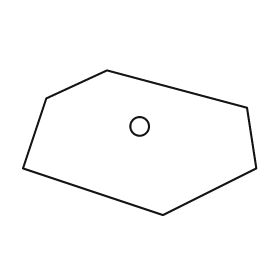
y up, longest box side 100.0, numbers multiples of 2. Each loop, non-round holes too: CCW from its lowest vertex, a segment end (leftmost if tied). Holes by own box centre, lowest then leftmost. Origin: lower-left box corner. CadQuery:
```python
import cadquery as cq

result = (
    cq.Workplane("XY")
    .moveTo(60.0, 0.0)
    .lineTo(100.0, 20.0)
    .lineTo(96.0, 46.0)
    .lineTo(36.0, 62.0)
    .lineTo(10.0, 50.0)
    .lineTo(0.0, 20.0)
    .close()
    .moveTo(50.0, 38.0)
    .circle(4.0)
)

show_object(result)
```